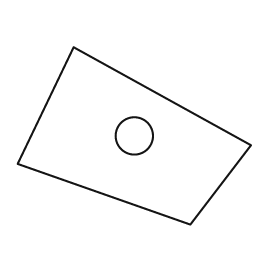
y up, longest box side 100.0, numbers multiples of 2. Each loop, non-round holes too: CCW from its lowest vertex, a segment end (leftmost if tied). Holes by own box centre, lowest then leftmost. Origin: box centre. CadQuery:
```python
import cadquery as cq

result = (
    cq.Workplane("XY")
    .moveTo(24.0, -38.0)
    .lineTo(50.0, -4.0)
    .lineTo(-26.0, 38.0)
    .lineTo(-50.0, -12.0)
    .close()
    .moveTo(0.0, 0.0)
    .circle(8.0)
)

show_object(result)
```